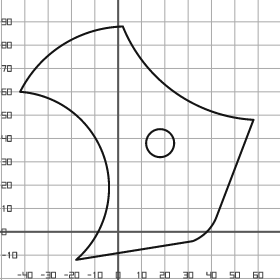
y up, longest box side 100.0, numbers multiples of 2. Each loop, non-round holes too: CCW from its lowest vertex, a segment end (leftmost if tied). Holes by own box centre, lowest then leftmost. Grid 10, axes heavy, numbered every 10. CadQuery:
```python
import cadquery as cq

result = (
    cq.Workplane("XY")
    .moveTo(-18.0, -12.0)
    .lineTo(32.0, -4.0)
    .threePointArc((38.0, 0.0), (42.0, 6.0))
    .lineTo(58.0, 48.0)
    .threePointArc((24.0, 60.0), (2.0, 88.0))
    .threePointArc((-24.0, 80.0), (-42.0, 60.0))
    .threePointArc((-6.0, 32.0), (-18.0, -12.0))
    .close()
    .moveTo(18.0, 38.0)
    .circle(6.0)
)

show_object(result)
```